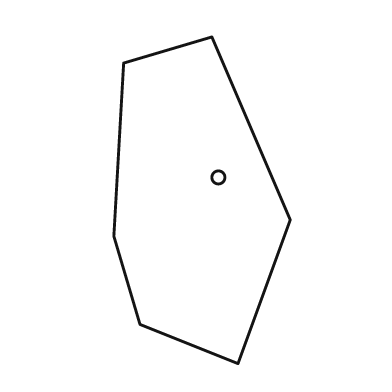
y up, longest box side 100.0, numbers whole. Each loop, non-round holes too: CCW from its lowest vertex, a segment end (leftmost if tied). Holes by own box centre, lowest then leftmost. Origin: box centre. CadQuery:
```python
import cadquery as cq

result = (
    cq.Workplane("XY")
    .moveTo(11.0, -50.0)
    .lineTo(27.0, -6.0)
    .lineTo(3.0, 50.0)
    .lineTo(-24.0, 42.0)
    .lineTo(-27.0, -11.0)
    .lineTo(-19.0, -38.0)
    .close()
    .moveTo(5.0, 7.0)
    .circle(2.0)
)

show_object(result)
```